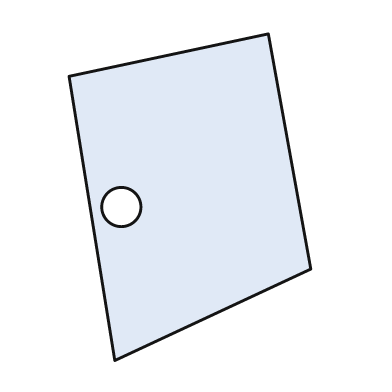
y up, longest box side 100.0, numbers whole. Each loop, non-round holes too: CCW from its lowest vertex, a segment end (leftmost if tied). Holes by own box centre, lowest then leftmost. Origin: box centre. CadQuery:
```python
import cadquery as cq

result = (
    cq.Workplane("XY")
    .moveTo(-23.0, -50.0)
    .lineTo(37.0, -22.0)
    .lineTo(24.0, 50.0)
    .lineTo(-37.0, 37.0)
    .close()
    .moveTo(-21.0, -3.0)
    .circle(6.0)
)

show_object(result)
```